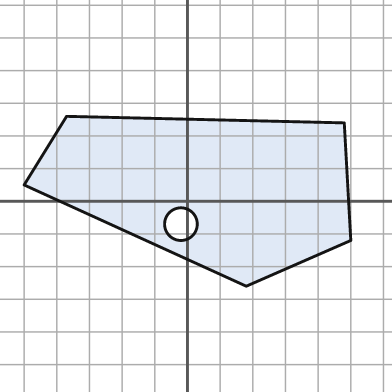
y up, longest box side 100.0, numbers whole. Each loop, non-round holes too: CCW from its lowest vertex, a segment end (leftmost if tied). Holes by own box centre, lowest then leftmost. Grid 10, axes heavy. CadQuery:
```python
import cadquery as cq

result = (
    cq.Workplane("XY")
    .moveTo(18.0, -26.0)
    .lineTo(50.0, -12.0)
    .lineTo(48.0, 24.0)
    .lineTo(-37.0, 26.0)
    .lineTo(-50.0, 5.0)
    .close()
    .moveTo(-2.0, -7.0)
    .circle(5.0)
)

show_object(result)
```